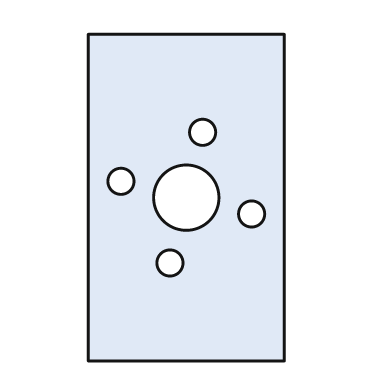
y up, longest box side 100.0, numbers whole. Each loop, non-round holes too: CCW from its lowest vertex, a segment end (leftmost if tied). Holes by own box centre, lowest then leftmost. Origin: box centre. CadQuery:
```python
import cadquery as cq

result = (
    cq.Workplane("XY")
    .moveTo(-30.0, -50.0)
    .lineTo(30.0, -50.0)
    .lineTo(30.0, 50.0)
    .lineTo(-30.0, 50.0)
    .close()
    .moveTo(-5.0, -20.0)
    .circle(4.0)
    .moveTo(20.0, -5.0)
    .circle(4.0)
    .moveTo(0.0, 0.0)
    .circle(10.0)
    .moveTo(-20.0, 5.0)
    .circle(4.0)
    .moveTo(5.0, 20.0)
    .circle(4.0)
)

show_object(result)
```